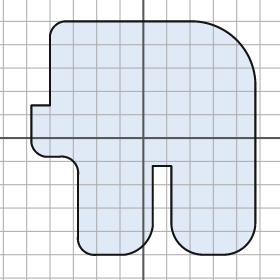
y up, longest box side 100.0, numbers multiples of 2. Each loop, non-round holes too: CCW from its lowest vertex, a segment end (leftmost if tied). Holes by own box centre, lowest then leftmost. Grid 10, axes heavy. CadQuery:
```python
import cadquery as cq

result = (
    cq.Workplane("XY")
    .moveTo(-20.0, -50.0)
    .lineTo(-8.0, -50.0)
    .threePointArc((0.0, -46.0), (4.0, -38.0))
    .lineTo(4.0, -12.0)
    .lineTo(12.0, -12.0)
    .lineTo(12.0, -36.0)
    .threePointArc((16.0, -46.0), (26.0, -50.0))
    .lineTo(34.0, -50.0)
    .threePointArc((44.0, -46.0), (48.0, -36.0))
    .lineTo(48.0, 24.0)
    .threePointArc((40.0, 42.0), (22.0, 50.0))
    .lineTo(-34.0, 50.0)
    .threePointArc((-38.0, 48.0), (-40.0, 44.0))
    .lineTo(-40.0, 14.0)
    .lineTo(-48.0, 14.0)
    .lineTo(-48.0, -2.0)
    .threePointArc((-46.0, -6.0), (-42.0, -8.0))
    .lineTo(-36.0, -8.0)
    .threePointArc((-30.0, -10.0), (-28.0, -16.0))
    .lineTo(-28.0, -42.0)
    .threePointArc((-26.0, -48.0), (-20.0, -50.0))
    .close()
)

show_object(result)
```